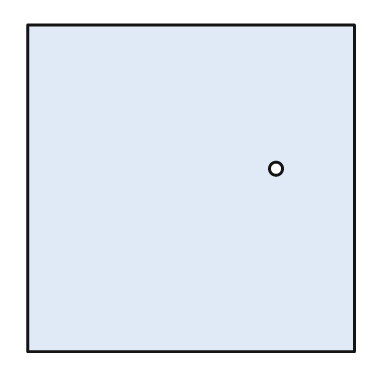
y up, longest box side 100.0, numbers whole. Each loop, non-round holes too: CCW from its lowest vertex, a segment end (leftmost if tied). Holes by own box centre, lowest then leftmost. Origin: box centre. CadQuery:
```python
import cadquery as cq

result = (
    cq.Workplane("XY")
    .moveTo(-50.0, -50.0)
    .lineTo(50.0, -50.0)
    .lineTo(50.0, 50.0)
    .lineTo(-50.0, 50.0)
    .close()
    .moveTo(26.0, 6.0)
    .circle(2.0)
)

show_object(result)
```